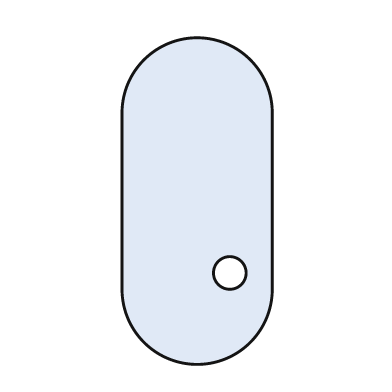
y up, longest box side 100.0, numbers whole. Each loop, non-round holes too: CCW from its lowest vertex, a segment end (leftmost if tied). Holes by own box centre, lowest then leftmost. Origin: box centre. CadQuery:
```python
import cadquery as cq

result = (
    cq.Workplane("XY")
    .moveTo(-23.0, -27.0)
    .threePointArc((0.0, -50.0), (23.0, -27.0))
    .lineTo(23.0, 27.0)
    .threePointArc((0.0, 50.0), (-23.0, 27.0))
    .close()
    .moveTo(10.0, -22.0)
    .circle(5.0)
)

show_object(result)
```